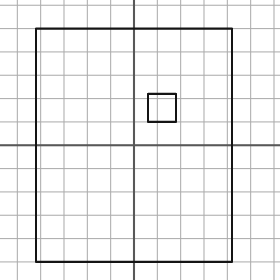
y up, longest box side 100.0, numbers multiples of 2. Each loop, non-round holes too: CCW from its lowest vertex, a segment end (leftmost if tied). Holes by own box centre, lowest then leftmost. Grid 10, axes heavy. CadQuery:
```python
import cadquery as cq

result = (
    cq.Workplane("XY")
    .moveTo(-42.0, -50.0)
    .lineTo(42.0, -50.0)
    .lineTo(42.0, 50.0)
    .lineTo(-42.0, 50.0)
    .close()
    .moveTo(6.0, 10.0)
    .lineTo(18.0, 10.0)
    .lineTo(18.0, 22.0)
    .lineTo(6.0, 22.0)
    .close()
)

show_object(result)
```